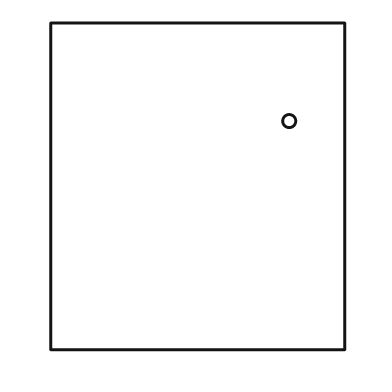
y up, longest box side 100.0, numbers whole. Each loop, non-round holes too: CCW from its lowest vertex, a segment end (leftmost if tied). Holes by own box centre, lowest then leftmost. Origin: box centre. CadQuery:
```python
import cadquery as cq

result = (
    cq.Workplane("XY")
    .moveTo(-45.0, -50.0)
    .lineTo(45.0, -50.0)
    .lineTo(45.0, 50.0)
    .lineTo(-45.0, 50.0)
    .close()
    .moveTo(28.0, 20.0)
    .circle(2.0)
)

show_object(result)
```